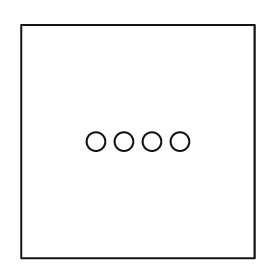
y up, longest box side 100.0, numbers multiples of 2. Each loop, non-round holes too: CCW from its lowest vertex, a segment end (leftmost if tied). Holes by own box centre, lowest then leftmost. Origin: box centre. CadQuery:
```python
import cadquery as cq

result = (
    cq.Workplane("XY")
    .moveTo(-50.0, -50.0)
    .lineTo(50.0, -50.0)
    .lineTo(50.0, 50.0)
    .lineTo(-50.0, 50.0)
    .close()
    .moveTo(-18.0, 0.0)
    .circle(4.0)
    .moveTo(-6.0, 0.0)
    .circle(4.0)
    .moveTo(6.0, 0.0)
    .circle(4.0)
    .moveTo(18.0, 0.0)
    .circle(4.0)
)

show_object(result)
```